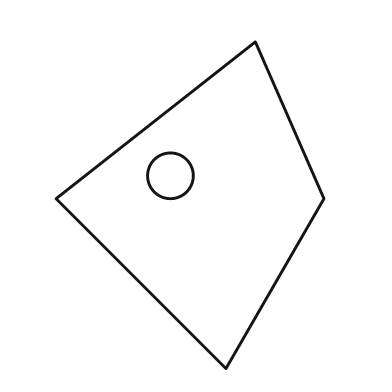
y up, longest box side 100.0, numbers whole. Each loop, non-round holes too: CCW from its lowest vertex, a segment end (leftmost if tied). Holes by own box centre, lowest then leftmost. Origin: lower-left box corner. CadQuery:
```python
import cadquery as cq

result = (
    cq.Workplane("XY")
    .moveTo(52.0, 0.0)
    .lineTo(82.0, 52.0)
    .lineTo(61.0, 100.0)
    .lineTo(0.0, 52.0)
    .close()
    .moveTo(35.0, 59.0)
    .circle(7.0)
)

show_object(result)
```